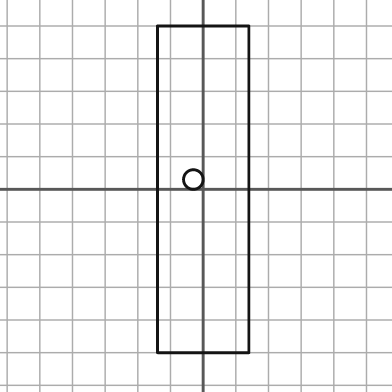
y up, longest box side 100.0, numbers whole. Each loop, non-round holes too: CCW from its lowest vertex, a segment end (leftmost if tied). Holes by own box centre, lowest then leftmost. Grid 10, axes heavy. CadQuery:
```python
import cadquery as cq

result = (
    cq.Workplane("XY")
    .moveTo(-14.0, -50.0)
    .lineTo(14.0, -50.0)
    .lineTo(14.0, 50.0)
    .lineTo(-14.0, 50.0)
    .close()
    .moveTo(-3.0, 3.0)
    .circle(3.0)
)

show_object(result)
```